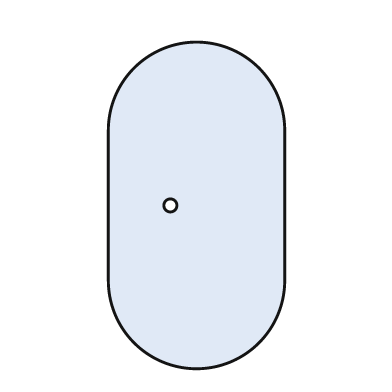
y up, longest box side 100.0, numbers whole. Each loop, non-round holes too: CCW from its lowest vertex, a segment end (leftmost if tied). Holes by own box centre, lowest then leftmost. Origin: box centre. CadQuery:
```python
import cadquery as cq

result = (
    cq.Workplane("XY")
    .moveTo(-27.0, -23.0)
    .threePointArc((0.0, -50.0), (27.0, -23.0))
    .lineTo(27.0, 23.0)
    .threePointArc((0.0, 50.0), (-27.0, 23.0))
    .close()
    .moveTo(-8.0, 0.0)
    .circle(2.0)
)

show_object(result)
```